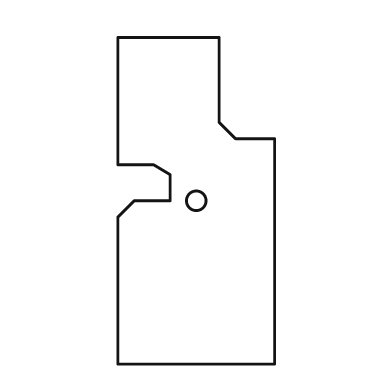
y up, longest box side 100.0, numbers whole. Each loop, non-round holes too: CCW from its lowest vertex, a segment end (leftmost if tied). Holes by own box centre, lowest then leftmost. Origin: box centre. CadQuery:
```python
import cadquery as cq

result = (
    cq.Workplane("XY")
    .moveTo(-24.0, -50.0)
    .lineTo(24.0, -50.0)
    .lineTo(24.0, 19.0)
    .lineTo(12.0, 19.0)
    .lineTo(7.0, 24.0)
    .lineTo(7.0, 50.0)
    .lineTo(-24.0, 50.0)
    .lineTo(-24.0, 11.0)
    .lineTo(-13.0, 11.0)
    .lineTo(-8.0, 8.0)
    .lineTo(-8.0, 0.0)
    .lineTo(-19.0, 0.0)
    .lineTo(-24.0, -5.0)
    .close()
    .moveTo(0.0, 0.0)
    .circle(3.0)
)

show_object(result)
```